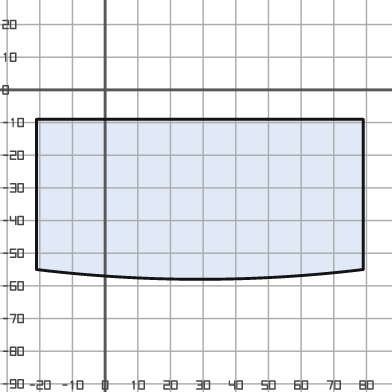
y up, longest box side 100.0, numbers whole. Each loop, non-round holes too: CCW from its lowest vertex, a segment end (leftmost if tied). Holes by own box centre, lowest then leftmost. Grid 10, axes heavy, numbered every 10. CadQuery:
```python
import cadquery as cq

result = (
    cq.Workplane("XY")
    .moveTo(-21.0, -55.0)
    .threePointArc((29.0, -58.0), (79.0, -55.0))
    .lineTo(79.0, -9.0)
    .lineTo(-21.0, -9.0)
    .close()
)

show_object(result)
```